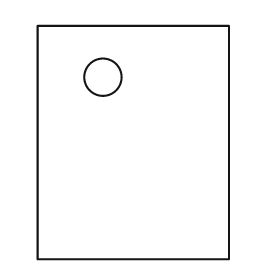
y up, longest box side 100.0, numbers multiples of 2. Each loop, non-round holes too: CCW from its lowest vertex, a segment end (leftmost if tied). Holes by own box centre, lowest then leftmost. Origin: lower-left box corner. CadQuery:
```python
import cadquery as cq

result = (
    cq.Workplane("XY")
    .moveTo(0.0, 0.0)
    .lineTo(82.0, 0.0)
    .lineTo(82.0, 100.0)
    .lineTo(0.0, 100.0)
    .close()
    .moveTo(28.0, 78.0)
    .circle(8.0)
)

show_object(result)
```